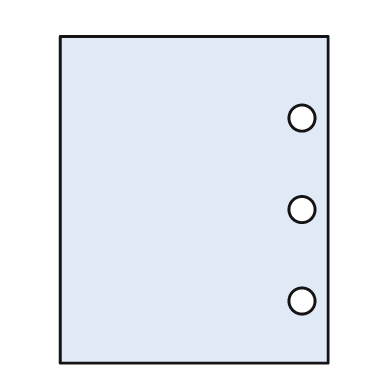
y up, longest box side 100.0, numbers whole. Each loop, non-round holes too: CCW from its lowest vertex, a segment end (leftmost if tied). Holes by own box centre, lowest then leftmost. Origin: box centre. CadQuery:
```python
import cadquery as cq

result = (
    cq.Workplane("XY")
    .moveTo(-41.0, -50.0)
    .lineTo(41.0, -50.0)
    .lineTo(41.0, 50.0)
    .lineTo(-41.0, 50.0)
    .close()
    .moveTo(33.0, -31.0)
    .circle(4.0)
    .moveTo(33.0, -3.0)
    .circle(4.0)
    .moveTo(33.0, 25.0)
    .circle(4.0)
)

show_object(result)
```